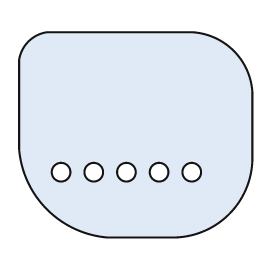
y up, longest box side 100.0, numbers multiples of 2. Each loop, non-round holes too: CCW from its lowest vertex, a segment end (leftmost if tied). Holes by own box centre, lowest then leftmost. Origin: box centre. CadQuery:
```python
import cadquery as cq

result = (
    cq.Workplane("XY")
    .moveTo(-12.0, -44.0)
    .lineTo(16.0, -44.0)
    .threePointArc((40.0, -34.0), (50.0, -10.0))
    .lineTo(50.0, 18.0)
    .threePointArc((42.0, 36.0), (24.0, 44.0))
    .lineTo(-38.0, 44.0)
    .threePointArc((-46.0, 40.0), (-50.0, 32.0))
    .lineTo(-50.0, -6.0)
    .threePointArc((-38.0, -32.0), (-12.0, -44.0))
    .close()
    .moveTo(-32.0, -16.0)
    .circle(4.0)
    .moveTo(-18.0, -16.0)
    .circle(4.0)
    .moveTo(-4.0, -16.0)
    .circle(4.0)
    .moveTo(10.0, -16.0)
    .circle(4.0)
    .moveTo(24.0, -16.0)
    .circle(4.0)
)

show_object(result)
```